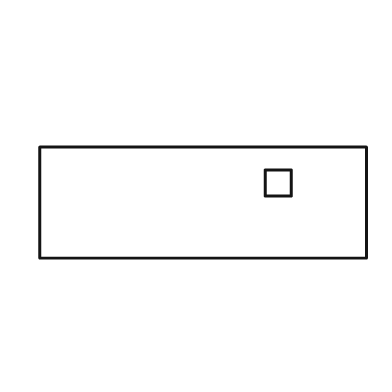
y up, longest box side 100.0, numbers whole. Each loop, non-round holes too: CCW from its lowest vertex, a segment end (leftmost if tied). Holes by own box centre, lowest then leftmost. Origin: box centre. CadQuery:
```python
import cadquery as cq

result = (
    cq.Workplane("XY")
    .moveTo(-50.0, -17.0)
    .lineTo(50.0, -17.0)
    .lineTo(50.0, 17.0)
    .lineTo(-50.0, 17.0)
    .close()
    .moveTo(19.0, 2.0)
    .lineTo(27.0, 2.0)
    .lineTo(27.0, 10.0)
    .lineTo(19.0, 10.0)
    .close()
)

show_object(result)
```